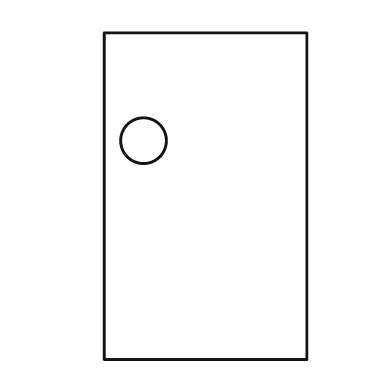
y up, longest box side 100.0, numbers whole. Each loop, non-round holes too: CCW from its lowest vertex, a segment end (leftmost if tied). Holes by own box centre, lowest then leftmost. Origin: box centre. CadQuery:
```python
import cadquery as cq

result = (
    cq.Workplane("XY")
    .moveTo(-31.0, -50.0)
    .lineTo(31.0, -50.0)
    .lineTo(31.0, 50.0)
    .lineTo(-31.0, 50.0)
    .close()
    .moveTo(-19.0, 17.0)
    .circle(7.0)
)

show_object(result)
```